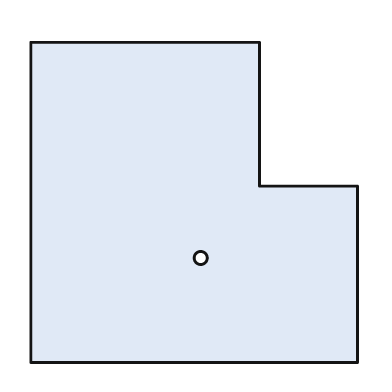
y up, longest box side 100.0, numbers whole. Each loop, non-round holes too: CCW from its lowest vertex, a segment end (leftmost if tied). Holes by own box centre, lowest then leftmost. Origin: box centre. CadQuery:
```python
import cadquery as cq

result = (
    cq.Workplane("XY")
    .moveTo(-50.0, -49.0)
    .lineTo(50.0, -49.0)
    .lineTo(50.0, 5.0)
    .lineTo(20.0, 5.0)
    .lineTo(20.0, 49.0)
    .lineTo(-50.0, 49.0)
    .close()
    .moveTo(2.0, -17.0)
    .circle(2.0)
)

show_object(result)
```